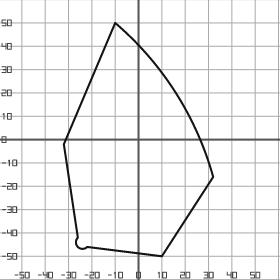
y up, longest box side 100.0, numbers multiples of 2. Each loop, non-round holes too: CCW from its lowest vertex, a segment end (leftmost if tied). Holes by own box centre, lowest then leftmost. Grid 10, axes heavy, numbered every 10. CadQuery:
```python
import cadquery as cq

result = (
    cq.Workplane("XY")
    .moveTo(10.0, -50.0)
    .lineTo(32.0, -16.0)
    .threePointArc((16.0, 20.0), (-10.0, 50.0))
    .lineTo(-32.0, -2.0)
    .lineTo(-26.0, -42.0)
    .threePointArc((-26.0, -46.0), (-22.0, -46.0))
    .close()
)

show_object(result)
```